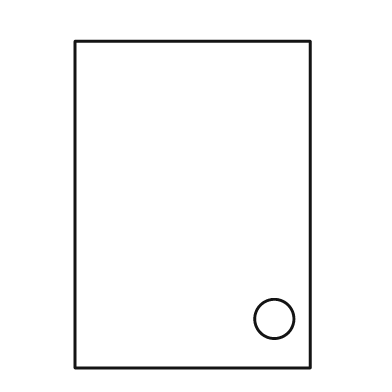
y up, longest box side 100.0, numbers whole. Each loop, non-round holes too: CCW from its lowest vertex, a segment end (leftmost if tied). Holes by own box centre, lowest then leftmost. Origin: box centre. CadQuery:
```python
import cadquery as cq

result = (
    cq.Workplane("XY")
    .moveTo(-36.0, -50.0)
    .lineTo(36.0, -50.0)
    .lineTo(36.0, 50.0)
    .lineTo(-36.0, 50.0)
    .close()
    .moveTo(25.0, -35.0)
    .circle(6.0)
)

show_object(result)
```